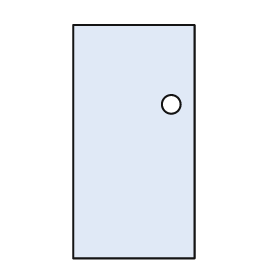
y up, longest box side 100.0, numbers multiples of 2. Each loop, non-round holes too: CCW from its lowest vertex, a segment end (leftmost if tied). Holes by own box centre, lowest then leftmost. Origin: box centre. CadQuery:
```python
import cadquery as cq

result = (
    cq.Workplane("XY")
    .moveTo(-26.0, -50.0)
    .lineTo(26.0, -50.0)
    .lineTo(26.0, 50.0)
    .lineTo(-26.0, 50.0)
    .close()
    .moveTo(16.0, 16.0)
    .circle(4.0)
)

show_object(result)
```